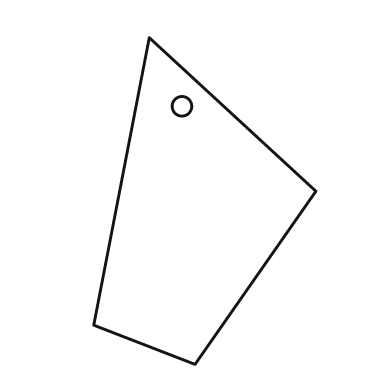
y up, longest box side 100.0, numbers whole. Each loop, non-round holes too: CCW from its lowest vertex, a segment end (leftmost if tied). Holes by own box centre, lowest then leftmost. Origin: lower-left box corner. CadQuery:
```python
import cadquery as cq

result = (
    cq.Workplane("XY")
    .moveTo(31.0, 0.0)
    .lineTo(68.0, 53.0)
    .lineTo(17.0, 100.0)
    .lineTo(0.0, 12.0)
    .close()
    .moveTo(27.0, 79.0)
    .circle(3.0)
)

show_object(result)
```